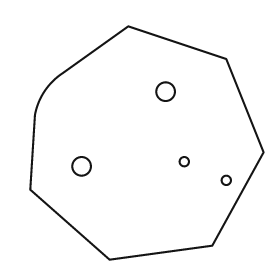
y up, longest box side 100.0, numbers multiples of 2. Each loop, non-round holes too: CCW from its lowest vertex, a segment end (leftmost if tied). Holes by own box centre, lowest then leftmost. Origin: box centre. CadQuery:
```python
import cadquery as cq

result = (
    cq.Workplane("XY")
    .moveTo(-16.0, -50.0)
    .lineTo(28.0, -44.0)
    .lineTo(50.0, -4.0)
    .lineTo(34.0, 36.0)
    .lineTo(-8.0, 50.0)
    .lineTo(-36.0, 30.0)
    .threePointArc((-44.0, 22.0), (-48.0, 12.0))
    .lineTo(-50.0, -20.0)
    .close()
    .moveTo(34.0, -16.0)
    .circle(2.0)
    .moveTo(-28.0, -10.0)
    .circle(4.0)
    .moveTo(16.0, -8.0)
    .circle(2.0)
    .moveTo(8.0, 22.0)
    .circle(4.0)
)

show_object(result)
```